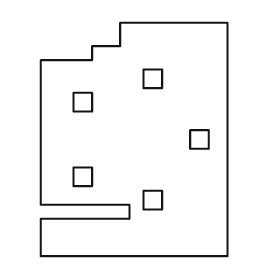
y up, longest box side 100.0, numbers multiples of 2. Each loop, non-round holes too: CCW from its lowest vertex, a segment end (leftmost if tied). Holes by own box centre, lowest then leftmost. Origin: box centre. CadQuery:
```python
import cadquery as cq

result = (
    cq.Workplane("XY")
    .moveTo(-40.0, -50.0)
    .lineTo(40.0, -50.0)
    .lineTo(40.0, 50.0)
    .lineTo(-6.0, 50.0)
    .lineTo(-6.0, 40.0)
    .lineTo(-18.0, 40.0)
    .lineTo(-18.0, 34.0)
    .lineTo(-40.0, 34.0)
    .lineTo(-40.0, -28.0)
    .lineTo(-2.0, -28.0)
    .lineTo(-2.0, -34.0)
    .lineTo(-40.0, -34.0)
    .close()
    .moveTo(4.0, -30.0)
    .lineTo(12.0, -30.0)
    .lineTo(12.0, -22.0)
    .lineTo(4.0, -22.0)
    .close()
    .moveTo(-26.0, -20.0)
    .lineTo(-18.0, -20.0)
    .lineTo(-18.0, -12.0)
    .lineTo(-26.0, -12.0)
    .close()
    .moveTo(24.0, -4.0)
    .lineTo(32.0, -4.0)
    .lineTo(32.0, 4.0)
    .lineTo(24.0, 4.0)
    .close()
    .moveTo(-26.0, 12.0)
    .lineTo(-18.0, 12.0)
    .lineTo(-18.0, 20.0)
    .lineTo(-26.0, 20.0)
    .close()
    .moveTo(4.0, 22.0)
    .lineTo(12.0, 22.0)
    .lineTo(12.0, 30.0)
    .lineTo(4.0, 30.0)
    .close()
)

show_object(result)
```